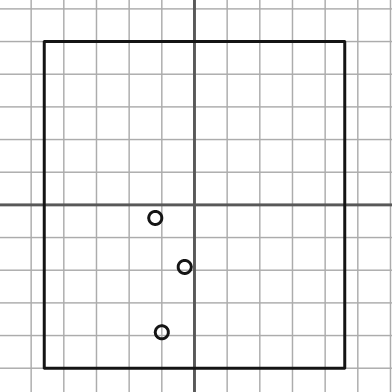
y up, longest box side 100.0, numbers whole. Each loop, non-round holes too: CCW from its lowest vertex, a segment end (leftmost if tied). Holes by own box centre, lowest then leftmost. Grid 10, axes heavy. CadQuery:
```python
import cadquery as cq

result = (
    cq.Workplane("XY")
    .moveTo(-46.0, -50.0)
    .lineTo(46.0, -50.0)
    .lineTo(46.0, 50.0)
    .lineTo(-46.0, 50.0)
    .close()
    .moveTo(-10.0, -39.0)
    .circle(2.0)
    .moveTo(-3.0, -19.0)
    .circle(2.0)
    .moveTo(-12.0, -4.0)
    .circle(2.0)
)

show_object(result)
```